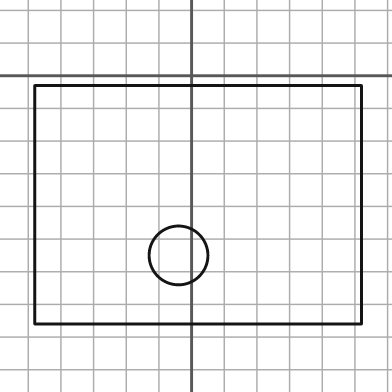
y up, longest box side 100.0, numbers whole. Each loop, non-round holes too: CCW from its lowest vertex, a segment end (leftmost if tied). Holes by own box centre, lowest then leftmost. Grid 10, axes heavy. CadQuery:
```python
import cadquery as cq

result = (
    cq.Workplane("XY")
    .moveTo(-48.0, -76.0)
    .lineTo(52.0, -76.0)
    .lineTo(52.0, -3.0)
    .lineTo(-48.0, -3.0)
    .close()
    .moveTo(-4.0, -55.0)
    .circle(9.0)
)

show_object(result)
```